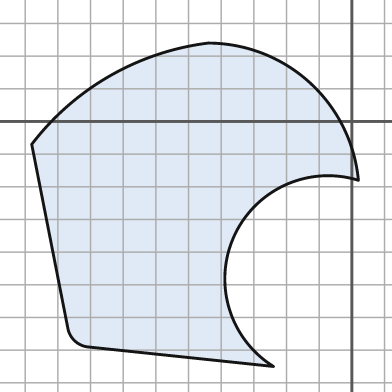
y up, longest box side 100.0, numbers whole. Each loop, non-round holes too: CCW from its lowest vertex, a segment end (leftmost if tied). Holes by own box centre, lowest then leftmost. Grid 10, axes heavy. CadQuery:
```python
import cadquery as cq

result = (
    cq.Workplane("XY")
    .moveTo(-24.0, -75.0)
    .threePointArc((-36.0, -35.0), (2.0, -18.0))
    .threePointArc((-13.0, 12.0), (-44.0, 24.0))
    .threePointArc((-74.0, 14.0), (-98.0, -7.0))
    .lineTo(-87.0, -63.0)
    .threePointArc((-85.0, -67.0), (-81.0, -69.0))
    .close()
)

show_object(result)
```